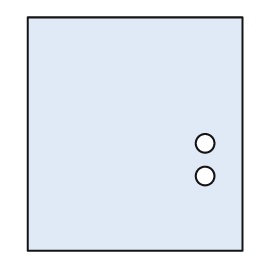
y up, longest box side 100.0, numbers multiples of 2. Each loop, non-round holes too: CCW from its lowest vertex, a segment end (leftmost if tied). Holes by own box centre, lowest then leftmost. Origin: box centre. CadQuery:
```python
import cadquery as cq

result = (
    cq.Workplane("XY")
    .moveTo(-46.0, -50.0)
    .lineTo(46.0, -50.0)
    .lineTo(46.0, 50.0)
    .lineTo(-46.0, 50.0)
    .close()
    .moveTo(30.0, -18.0)
    .circle(4.0)
    .moveTo(30.0, -4.0)
    .circle(4.0)
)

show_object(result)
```